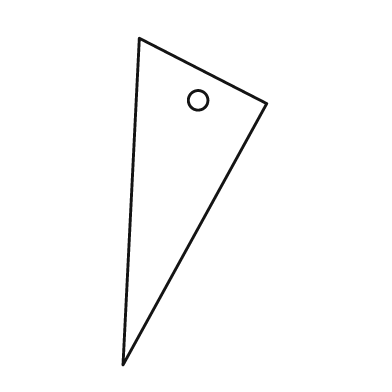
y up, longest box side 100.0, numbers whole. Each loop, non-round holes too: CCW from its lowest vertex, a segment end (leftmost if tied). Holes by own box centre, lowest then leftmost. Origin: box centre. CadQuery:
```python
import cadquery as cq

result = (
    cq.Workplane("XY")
    .moveTo(-22.0, -50.0)
    .lineTo(22.0, 30.0)
    .lineTo(-17.0, 50.0)
    .close()
    .moveTo(1.0, 31.0)
    .circle(3.0)
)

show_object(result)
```